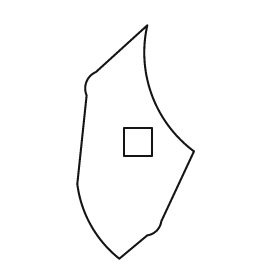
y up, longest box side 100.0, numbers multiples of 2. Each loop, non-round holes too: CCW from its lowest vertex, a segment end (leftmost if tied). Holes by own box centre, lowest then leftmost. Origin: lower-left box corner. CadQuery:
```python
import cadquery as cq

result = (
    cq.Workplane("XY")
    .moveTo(18.0, 0.0)
    .lineTo(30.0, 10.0)
    .threePointArc((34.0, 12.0), (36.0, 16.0))
    .lineTo(50.0, 46.0)
    .threePointArc((32.0, 70.0), (30.0, 100.0))
    .lineTo(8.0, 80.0)
    .threePointArc((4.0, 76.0), (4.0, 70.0))
    .lineTo(0.0, 32.0)
    .threePointArc((6.0, 14.0), (18.0, 0.0))
    .close()
    .moveTo(20.0, 44.0)
    .lineTo(32.0, 44.0)
    .lineTo(32.0, 56.0)
    .lineTo(20.0, 56.0)
    .close()
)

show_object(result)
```